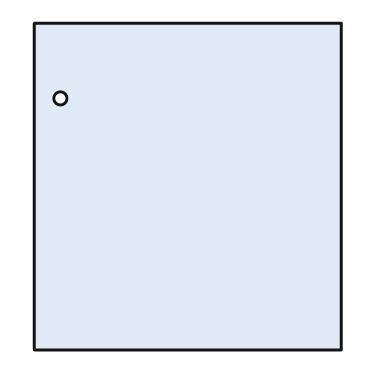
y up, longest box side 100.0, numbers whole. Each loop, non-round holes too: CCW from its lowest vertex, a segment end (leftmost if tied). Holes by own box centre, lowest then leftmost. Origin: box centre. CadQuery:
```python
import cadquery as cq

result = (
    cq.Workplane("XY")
    .moveTo(-47.0, -50.0)
    .lineTo(47.0, -50.0)
    .lineTo(47.0, 50.0)
    .lineTo(-47.0, 50.0)
    .close()
    .moveTo(-39.0, 27.0)
    .circle(2.0)
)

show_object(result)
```